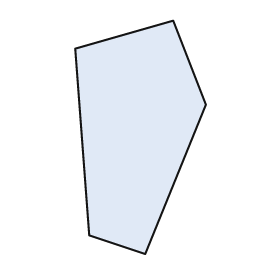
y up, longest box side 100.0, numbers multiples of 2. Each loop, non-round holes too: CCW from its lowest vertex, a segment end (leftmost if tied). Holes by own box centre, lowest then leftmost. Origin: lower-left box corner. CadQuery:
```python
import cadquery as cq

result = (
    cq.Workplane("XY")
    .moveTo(30.0, 0.0)
    .lineTo(56.0, 64.0)
    .lineTo(42.0, 100.0)
    .lineTo(0.0, 88.0)
    .lineTo(6.0, 8.0)
    .close()
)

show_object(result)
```